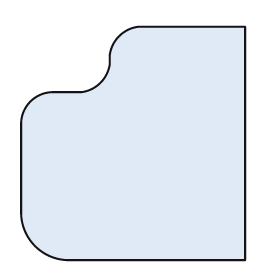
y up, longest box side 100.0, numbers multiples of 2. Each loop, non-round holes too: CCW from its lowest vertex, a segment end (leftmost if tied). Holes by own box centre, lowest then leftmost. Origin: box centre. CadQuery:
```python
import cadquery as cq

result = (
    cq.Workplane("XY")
    .moveTo(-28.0, -50.0)
    .lineTo(48.0, -50.0)
    .lineTo(48.0, 50.0)
    .lineTo(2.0, 50.0)
    .threePointArc((-6.0, 46.0), (-10.0, 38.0))
    .lineTo(-10.0, 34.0)
    .threePointArc((-14.0, 26.0), (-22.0, 22.0))
    .lineTo(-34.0, 22.0)
    .threePointArc((-44.0, 18.0), (-48.0, 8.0))
    .lineTo(-48.0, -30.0)
    .threePointArc((-42.0, -44.0), (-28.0, -50.0))
    .close()
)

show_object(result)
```